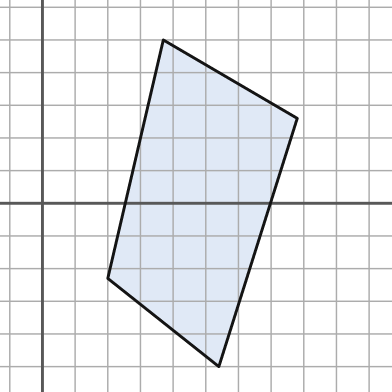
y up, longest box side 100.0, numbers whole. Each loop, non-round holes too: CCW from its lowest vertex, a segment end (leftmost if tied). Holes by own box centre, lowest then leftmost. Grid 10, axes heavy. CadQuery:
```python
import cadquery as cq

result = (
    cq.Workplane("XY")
    .moveTo(54.0, -50.0)
    .lineTo(78.0, 26.0)
    .lineTo(37.0, 50.0)
    .lineTo(20.0, -23.0)
    .close()
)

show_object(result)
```